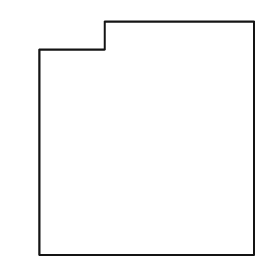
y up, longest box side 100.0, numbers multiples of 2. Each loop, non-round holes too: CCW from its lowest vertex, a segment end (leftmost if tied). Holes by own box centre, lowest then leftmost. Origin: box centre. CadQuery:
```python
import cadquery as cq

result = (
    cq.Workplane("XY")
    .moveTo(-46.0, -50.0)
    .lineTo(46.0, -50.0)
    .lineTo(46.0, 50.0)
    .lineTo(-18.0, 50.0)
    .lineTo(-18.0, 38.0)
    .lineTo(-46.0, 38.0)
    .close()
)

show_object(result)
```